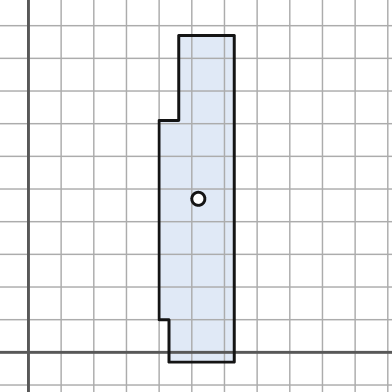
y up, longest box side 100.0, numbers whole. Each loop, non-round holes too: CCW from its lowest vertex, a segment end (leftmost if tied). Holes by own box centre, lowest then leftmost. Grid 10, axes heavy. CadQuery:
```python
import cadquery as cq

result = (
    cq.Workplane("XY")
    .moveTo(43.0, -3.0)
    .lineTo(63.0, -3.0)
    .lineTo(63.0, 97.0)
    .lineTo(46.0, 97.0)
    .lineTo(46.0, 71.0)
    .lineTo(40.0, 71.0)
    .lineTo(40.0, 10.0)
    .lineTo(43.0, 10.0)
    .close()
    .moveTo(52.0, 47.0)
    .circle(2.0)
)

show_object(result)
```